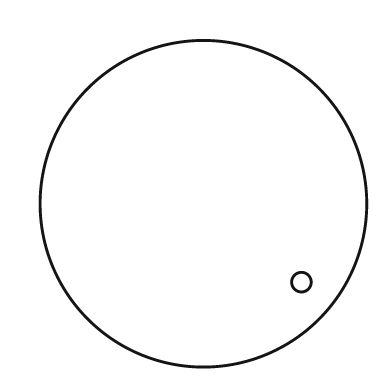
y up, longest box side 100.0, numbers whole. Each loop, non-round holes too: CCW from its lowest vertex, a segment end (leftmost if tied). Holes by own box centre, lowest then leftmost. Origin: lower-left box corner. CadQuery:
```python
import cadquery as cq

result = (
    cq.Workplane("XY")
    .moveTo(50.0, 50.0)
    .circle(50.0)
    .moveTo(80.0, 26.0)
    .circle(3.0)
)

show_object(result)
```